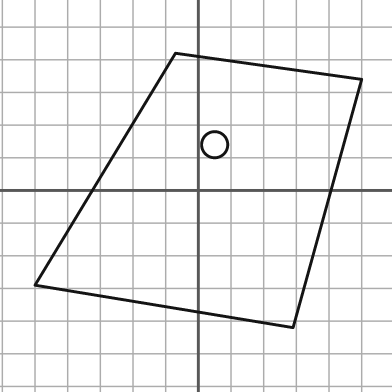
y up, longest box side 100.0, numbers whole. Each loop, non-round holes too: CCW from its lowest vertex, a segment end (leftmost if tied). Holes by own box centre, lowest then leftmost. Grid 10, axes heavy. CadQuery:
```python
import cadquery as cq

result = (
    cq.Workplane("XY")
    .moveTo(29.0, -42.0)
    .lineTo(50.0, 34.0)
    .lineTo(-7.0, 42.0)
    .lineTo(-50.0, -29.0)
    .close()
    .moveTo(5.0, 14.0)
    .circle(4.0)
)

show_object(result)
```